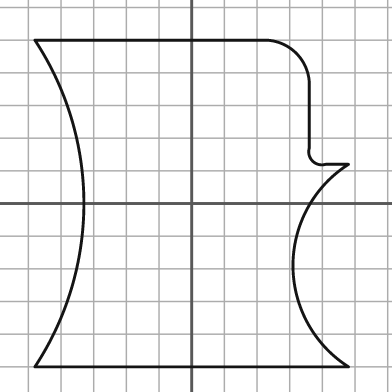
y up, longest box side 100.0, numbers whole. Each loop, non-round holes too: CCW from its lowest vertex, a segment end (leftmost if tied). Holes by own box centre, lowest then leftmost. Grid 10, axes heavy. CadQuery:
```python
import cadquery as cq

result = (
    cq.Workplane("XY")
    .moveTo(-48.0, -50.0)
    .lineTo(48.0, -50.0)
    .threePointArc((31.0, -19.0), (48.0, 12.0))
    .lineTo(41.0, 12.0)
    .threePointArc((37.0, 13.0), (36.0, 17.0))
    .lineTo(36.0, 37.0)
    .threePointArc((32.0, 46.0), (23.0, 50.0))
    .lineTo(-48.0, 50.0)
    .threePointArc((-33.0, 0.0), (-48.0, -50.0))
    .close()
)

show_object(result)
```